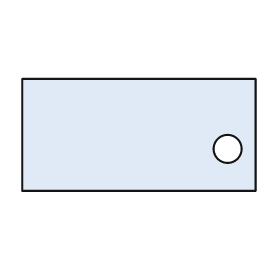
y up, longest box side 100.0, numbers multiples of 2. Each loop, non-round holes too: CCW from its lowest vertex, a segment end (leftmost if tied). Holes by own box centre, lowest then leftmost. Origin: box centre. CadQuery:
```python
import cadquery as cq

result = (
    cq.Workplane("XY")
    .moveTo(-50.0, -24.0)
    .lineTo(50.0, -24.0)
    .lineTo(50.0, 24.0)
    .lineTo(-50.0, 24.0)
    .close()
    .moveTo(38.0, -6.0)
    .circle(6.0)
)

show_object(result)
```